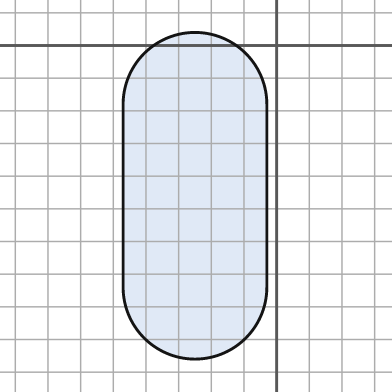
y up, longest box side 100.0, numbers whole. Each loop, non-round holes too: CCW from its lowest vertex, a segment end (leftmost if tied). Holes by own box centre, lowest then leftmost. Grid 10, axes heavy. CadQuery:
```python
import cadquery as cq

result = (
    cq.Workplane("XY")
    .moveTo(-47.0, -74.0)
    .threePointArc((-25.0, -96.0), (-3.0, -74.0))
    .lineTo(-3.0, -18.0)
    .threePointArc((-25.0, 4.0), (-47.0, -18.0))
    .close()
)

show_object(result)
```